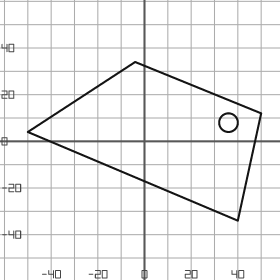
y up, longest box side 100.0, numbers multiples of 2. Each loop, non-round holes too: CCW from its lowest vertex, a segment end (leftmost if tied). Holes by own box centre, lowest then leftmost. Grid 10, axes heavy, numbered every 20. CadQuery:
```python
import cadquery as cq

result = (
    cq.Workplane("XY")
    .moveTo(40.0, -34.0)
    .lineTo(50.0, 12.0)
    .lineTo(-4.0, 34.0)
    .lineTo(-50.0, 4.0)
    .close()
    .moveTo(36.0, 8.0)
    .circle(4.0)
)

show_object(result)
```